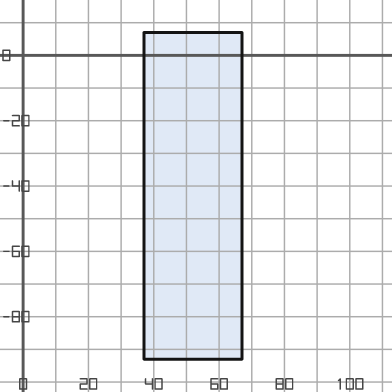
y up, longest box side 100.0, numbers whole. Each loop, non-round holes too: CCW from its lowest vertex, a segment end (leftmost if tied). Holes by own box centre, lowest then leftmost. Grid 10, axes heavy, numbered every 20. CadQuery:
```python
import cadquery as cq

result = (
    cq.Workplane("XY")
    .moveTo(37.0, -93.0)
    .lineTo(67.0, -93.0)
    .lineTo(67.0, 7.0)
    .lineTo(37.0, 7.0)
    .close()
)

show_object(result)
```